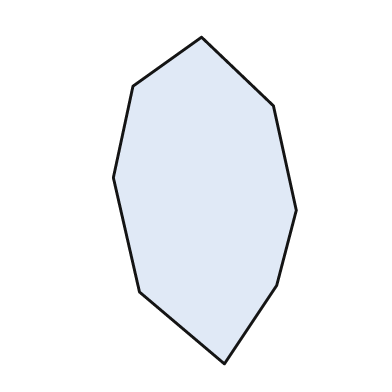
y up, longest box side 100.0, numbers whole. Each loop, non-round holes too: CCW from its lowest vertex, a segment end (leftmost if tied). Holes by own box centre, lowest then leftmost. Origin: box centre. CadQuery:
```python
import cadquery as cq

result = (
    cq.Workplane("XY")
    .moveTo(6.0, -50.0)
    .lineTo(22.0, -26.0)
    .lineTo(28.0, -3.0)
    .lineTo(21.0, 29.0)
    .lineTo(-1.0, 50.0)
    .lineTo(-22.0, 35.0)
    .lineTo(-28.0, 7.0)
    .lineTo(-20.0, -28.0)
    .close()
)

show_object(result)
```